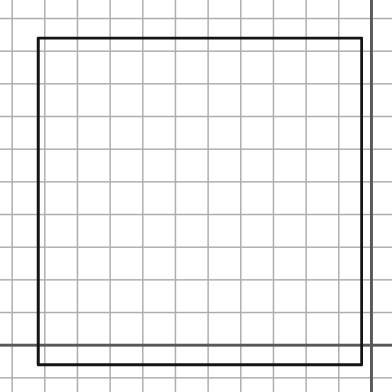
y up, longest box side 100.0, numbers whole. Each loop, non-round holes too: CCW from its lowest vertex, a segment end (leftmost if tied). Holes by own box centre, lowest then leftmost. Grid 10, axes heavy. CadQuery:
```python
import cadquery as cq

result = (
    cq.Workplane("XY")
    .moveTo(-102.0, -6.0)
    .lineTo(-3.0, -6.0)
    .lineTo(-3.0, 94.0)
    .lineTo(-102.0, 94.0)
    .close()
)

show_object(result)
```